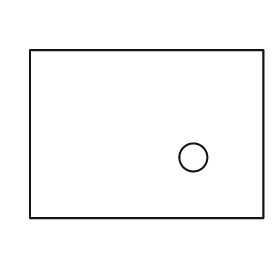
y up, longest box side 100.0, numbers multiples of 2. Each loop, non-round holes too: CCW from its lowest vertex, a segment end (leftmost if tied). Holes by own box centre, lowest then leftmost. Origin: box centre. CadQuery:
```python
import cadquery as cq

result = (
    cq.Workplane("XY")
    .moveTo(-50.0, -36.0)
    .lineTo(50.0, -36.0)
    .lineTo(50.0, 36.0)
    .lineTo(-50.0, 36.0)
    .close()
    .moveTo(20.0, -10.0)
    .circle(6.0)
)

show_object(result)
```